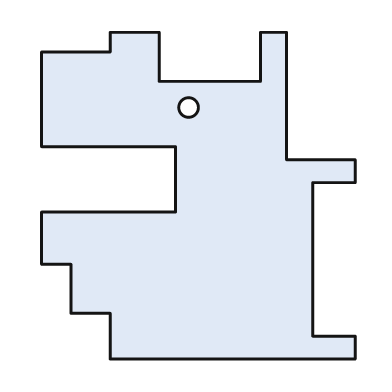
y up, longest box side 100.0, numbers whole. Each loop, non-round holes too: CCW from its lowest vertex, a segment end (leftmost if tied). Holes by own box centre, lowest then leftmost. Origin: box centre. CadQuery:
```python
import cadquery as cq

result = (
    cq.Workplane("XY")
    .moveTo(-27.0, -50.0)
    .lineTo(48.0, -50.0)
    .lineTo(48.0, -43.0)
    .lineTo(35.0, -43.0)
    .lineTo(35.0, 4.0)
    .lineTo(48.0, 4.0)
    .lineTo(48.0, 11.0)
    .lineTo(27.0, 11.0)
    .lineTo(27.0, 50.0)
    .lineTo(19.0, 50.0)
    .lineTo(19.0, 35.0)
    .lineTo(-12.0, 35.0)
    .lineTo(-12.0, 50.0)
    .lineTo(-27.0, 50.0)
    .lineTo(-27.0, 44.0)
    .lineTo(-48.0, 44.0)
    .lineTo(-48.0, 15.0)
    .lineTo(-7.0, 15.0)
    .lineTo(-7.0, -5.0)
    .lineTo(-48.0, -5.0)
    .lineTo(-48.0, -21.0)
    .lineTo(-39.0, -21.0)
    .lineTo(-39.0, -36.0)
    .lineTo(-27.0, -36.0)
    .close()
    .moveTo(-3.0, 27.0)
    .circle(3.0)
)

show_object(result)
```